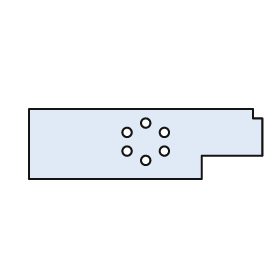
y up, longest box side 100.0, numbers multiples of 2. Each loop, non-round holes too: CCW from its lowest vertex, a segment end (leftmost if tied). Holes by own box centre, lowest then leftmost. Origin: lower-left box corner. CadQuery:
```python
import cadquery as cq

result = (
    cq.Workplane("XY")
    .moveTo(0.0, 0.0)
    .lineTo(74.0, 0.0)
    .lineTo(74.0, 10.0)
    .lineTo(100.0, 10.0)
    .lineTo(100.0, 26.0)
    .lineTo(96.0, 26.0)
    .lineTo(96.0, 30.0)
    .lineTo(0.0, 30.0)
    .close()
    .moveTo(50.0, 8.0)
    .circle(2.0)
    .moveTo(42.0, 12.0)
    .circle(2.0)
    .moveTo(58.0, 12.0)
    .circle(2.0)
    .moveTo(42.0, 20.0)
    .circle(2.0)
    .moveTo(58.0, 20.0)
    .circle(2.0)
    .moveTo(50.0, 24.0)
    .circle(2.0)
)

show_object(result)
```